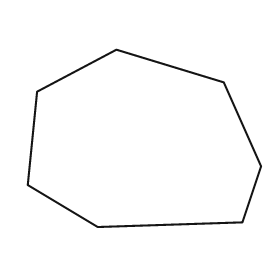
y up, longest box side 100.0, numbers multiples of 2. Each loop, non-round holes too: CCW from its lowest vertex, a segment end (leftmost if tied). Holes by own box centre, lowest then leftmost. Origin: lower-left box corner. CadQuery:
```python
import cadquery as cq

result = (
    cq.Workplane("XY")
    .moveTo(30.0, 0.0)
    .lineTo(92.0, 2.0)
    .lineTo(100.0, 26.0)
    .lineTo(84.0, 62.0)
    .lineTo(38.0, 76.0)
    .lineTo(4.0, 58.0)
    .lineTo(0.0, 18.0)
    .close()
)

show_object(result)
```